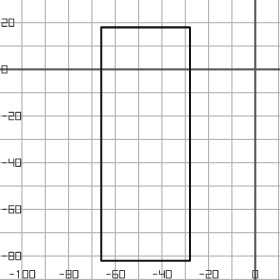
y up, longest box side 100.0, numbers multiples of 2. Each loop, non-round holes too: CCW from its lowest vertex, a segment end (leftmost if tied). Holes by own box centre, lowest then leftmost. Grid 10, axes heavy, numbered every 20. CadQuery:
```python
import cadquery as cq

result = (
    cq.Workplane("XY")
    .moveTo(-66.0, -82.0)
    .lineTo(-28.0, -82.0)
    .lineTo(-28.0, 18.0)
    .lineTo(-66.0, 18.0)
    .close()
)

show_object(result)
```